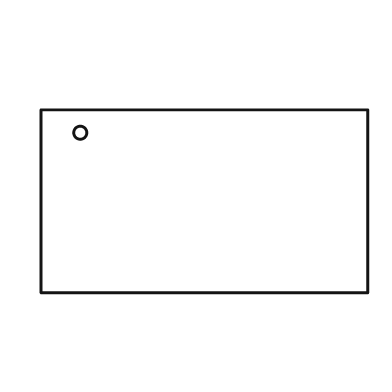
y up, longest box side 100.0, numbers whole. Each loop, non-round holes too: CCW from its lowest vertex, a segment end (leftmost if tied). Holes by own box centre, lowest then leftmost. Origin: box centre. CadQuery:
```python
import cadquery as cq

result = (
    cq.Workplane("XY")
    .moveTo(-50.0, -28.0)
    .lineTo(50.0, -28.0)
    .lineTo(50.0, 28.0)
    .lineTo(-50.0, 28.0)
    .close()
    .moveTo(-38.0, 21.0)
    .circle(2.0)
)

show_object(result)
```